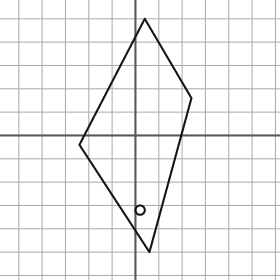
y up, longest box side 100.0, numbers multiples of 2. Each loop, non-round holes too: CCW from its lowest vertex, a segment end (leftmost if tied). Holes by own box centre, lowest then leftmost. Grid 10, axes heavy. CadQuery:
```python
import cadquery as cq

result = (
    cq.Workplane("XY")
    .moveTo(6.0, -50.0)
    .lineTo(24.0, 16.0)
    .lineTo(4.0, 50.0)
    .lineTo(-24.0, -4.0)
    .close()
    .moveTo(2.0, -32.0)
    .circle(2.0)
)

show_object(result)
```